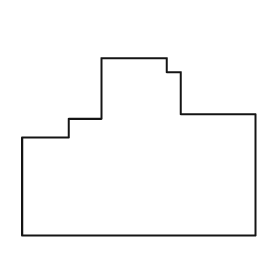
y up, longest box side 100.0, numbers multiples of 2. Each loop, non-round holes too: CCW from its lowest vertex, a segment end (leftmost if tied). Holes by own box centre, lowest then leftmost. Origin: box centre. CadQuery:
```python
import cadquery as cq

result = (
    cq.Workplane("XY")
    .moveTo(-50.0, -38.0)
    .lineTo(50.0, -38.0)
    .lineTo(50.0, 14.0)
    .lineTo(18.0, 14.0)
    .lineTo(18.0, 32.0)
    .lineTo(12.0, 32.0)
    .lineTo(12.0, 38.0)
    .lineTo(-16.0, 38.0)
    .lineTo(-16.0, 12.0)
    .lineTo(-30.0, 12.0)
    .lineTo(-30.0, 4.0)
    .lineTo(-50.0, 4.0)
    .close()
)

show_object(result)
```